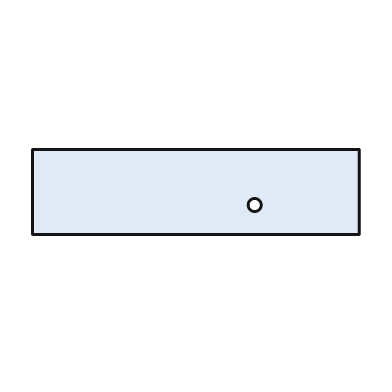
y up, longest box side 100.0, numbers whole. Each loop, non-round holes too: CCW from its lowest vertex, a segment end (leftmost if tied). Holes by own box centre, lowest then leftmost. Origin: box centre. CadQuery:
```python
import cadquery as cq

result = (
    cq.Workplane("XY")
    .moveTo(-50.0, -13.0)
    .lineTo(50.0, -13.0)
    .lineTo(50.0, 13.0)
    .lineTo(-50.0, 13.0)
    .close()
    .moveTo(18.0, -4.0)
    .circle(2.0)
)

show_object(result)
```